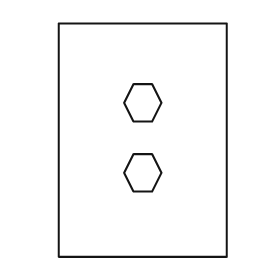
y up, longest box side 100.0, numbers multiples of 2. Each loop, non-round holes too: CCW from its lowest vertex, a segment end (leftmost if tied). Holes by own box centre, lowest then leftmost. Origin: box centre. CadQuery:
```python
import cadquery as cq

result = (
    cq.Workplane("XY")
    .moveTo(-36.0, -50.0)
    .lineTo(36.0, -50.0)
    .lineTo(36.0, 50.0)
    .lineTo(-36.0, 50.0)
    .close()
    .moveTo(-4.0, -22.0)
    .lineTo(4.0, -22.0)
    .lineTo(8.0, -14.0)
    .lineTo(4.0, -6.0)
    .lineTo(-4.0, -6.0)
    .lineTo(-8.0, -14.0)
    .close()
    .moveTo(-4.0, 8.0)
    .lineTo(4.0, 8.0)
    .lineTo(8.0, 16.0)
    .lineTo(4.0, 24.0)
    .lineTo(-4.0, 24.0)
    .lineTo(-8.0, 16.0)
    .close()
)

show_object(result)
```